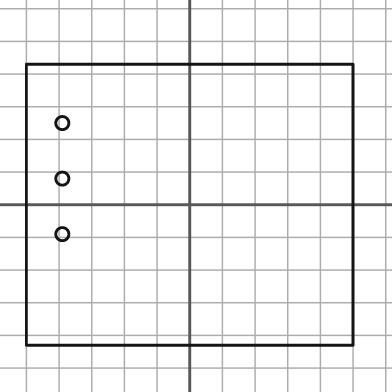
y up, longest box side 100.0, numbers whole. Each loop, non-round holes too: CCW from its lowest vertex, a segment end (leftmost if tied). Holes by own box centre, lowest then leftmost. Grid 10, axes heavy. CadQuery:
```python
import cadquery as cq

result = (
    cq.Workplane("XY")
    .moveTo(-50.0, -43.0)
    .lineTo(50.0, -43.0)
    .lineTo(50.0, 43.0)
    .lineTo(-50.0, 43.0)
    .close()
    .moveTo(-39.0, -9.0)
    .circle(2.0)
    .moveTo(-39.0, 8.0)
    .circle(2.0)
    .moveTo(-39.0, 25.0)
    .circle(2.0)
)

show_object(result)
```